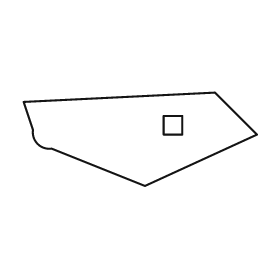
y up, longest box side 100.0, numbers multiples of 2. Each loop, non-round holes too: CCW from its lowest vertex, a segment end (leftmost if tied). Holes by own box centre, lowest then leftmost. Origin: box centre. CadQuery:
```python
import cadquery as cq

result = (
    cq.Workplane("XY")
    .moveTo(2.0, -20.0)
    .lineTo(50.0, 2.0)
    .lineTo(32.0, 20.0)
    .lineTo(-50.0, 16.0)
    .lineTo(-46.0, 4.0)
    .threePointArc((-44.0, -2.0), (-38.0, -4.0))
    .close()
    .moveTo(10.0, 2.0)
    .lineTo(18.0, 2.0)
    .lineTo(18.0, 10.0)
    .lineTo(10.0, 10.0)
    .close()
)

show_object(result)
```